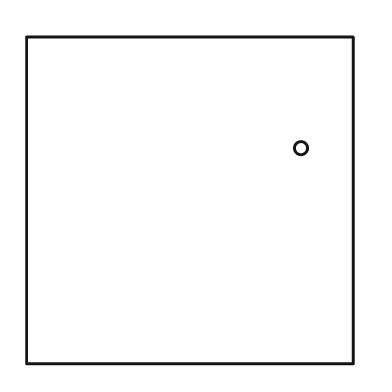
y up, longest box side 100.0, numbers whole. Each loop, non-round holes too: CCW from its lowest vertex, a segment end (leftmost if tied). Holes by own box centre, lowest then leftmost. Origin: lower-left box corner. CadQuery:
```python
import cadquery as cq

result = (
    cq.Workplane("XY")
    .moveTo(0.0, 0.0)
    .lineTo(100.0, 0.0)
    .lineTo(100.0, 100.0)
    .lineTo(0.0, 100.0)
    .close()
    .moveTo(84.0, 66.0)
    .circle(2.0)
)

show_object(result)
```